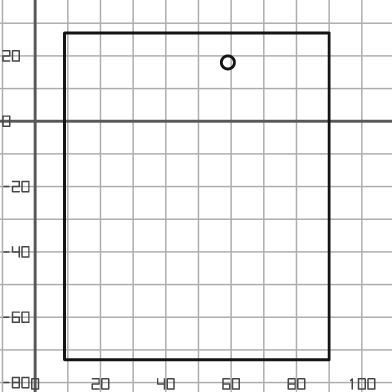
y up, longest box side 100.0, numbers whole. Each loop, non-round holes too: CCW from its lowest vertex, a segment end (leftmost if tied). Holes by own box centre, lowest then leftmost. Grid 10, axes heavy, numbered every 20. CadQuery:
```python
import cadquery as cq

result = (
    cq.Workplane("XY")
    .moveTo(9.0, -73.0)
    .lineTo(90.0, -73.0)
    .lineTo(90.0, 27.0)
    .lineTo(9.0, 27.0)
    .close()
    .moveTo(59.0, 18.0)
    .circle(2.0)
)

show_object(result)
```